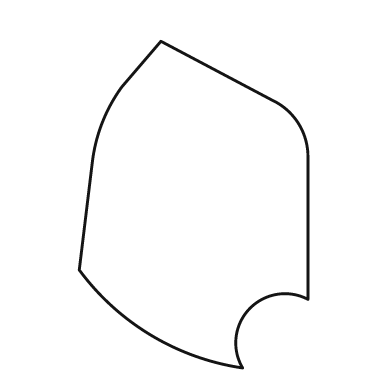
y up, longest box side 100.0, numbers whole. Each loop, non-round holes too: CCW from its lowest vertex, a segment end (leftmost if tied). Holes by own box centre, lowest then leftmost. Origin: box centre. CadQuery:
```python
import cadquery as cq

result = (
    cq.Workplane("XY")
    .moveTo(15.0, -50.0)
    .threePointArc((17.0, -32.0), (35.0, -29.0))
    .lineTo(35.0, 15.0)
    .threePointArc((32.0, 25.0), (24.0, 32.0))
    .lineTo(-10.0, 50.0)
    .lineTo(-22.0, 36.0)
    .threePointArc((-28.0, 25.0), (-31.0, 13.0))
    .lineTo(-35.0, -20.0)
    .threePointArc((-13.0, -40.0), (15.0, -50.0))
    .close()
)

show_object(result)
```